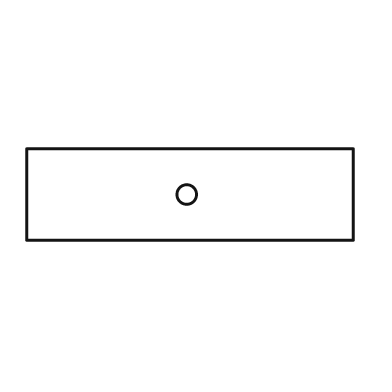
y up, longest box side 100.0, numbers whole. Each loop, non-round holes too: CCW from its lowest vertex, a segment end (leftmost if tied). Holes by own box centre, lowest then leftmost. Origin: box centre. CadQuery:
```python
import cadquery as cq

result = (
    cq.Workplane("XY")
    .moveTo(-50.0, -14.0)
    .lineTo(50.0, -14.0)
    .lineTo(50.0, 14.0)
    .lineTo(-50.0, 14.0)
    .close()
    .moveTo(-1.0, 0.0)
    .circle(3.0)
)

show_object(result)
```